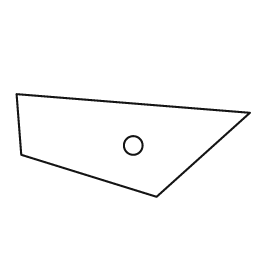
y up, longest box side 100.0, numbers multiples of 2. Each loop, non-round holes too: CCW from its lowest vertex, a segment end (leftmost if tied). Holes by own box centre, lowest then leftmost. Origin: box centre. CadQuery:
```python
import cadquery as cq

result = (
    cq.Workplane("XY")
    .moveTo(10.0, -22.0)
    .lineTo(50.0, 14.0)
    .lineTo(-50.0, 22.0)
    .lineTo(-48.0, -4.0)
    .close()
    .moveTo(0.0, 0.0)
    .circle(4.0)
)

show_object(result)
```